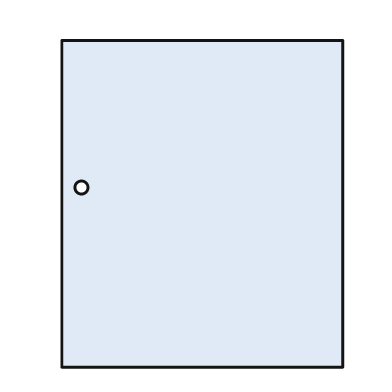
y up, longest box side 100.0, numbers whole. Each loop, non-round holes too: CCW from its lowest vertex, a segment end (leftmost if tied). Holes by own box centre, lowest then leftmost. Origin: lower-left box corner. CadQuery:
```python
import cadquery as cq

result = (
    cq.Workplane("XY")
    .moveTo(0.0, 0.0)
    .lineTo(86.0, 0.0)
    .lineTo(86.0, 100.0)
    .lineTo(0.0, 100.0)
    .close()
    .moveTo(6.0, 55.0)
    .circle(2.0)
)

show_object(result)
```